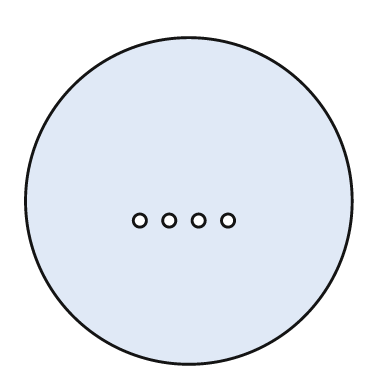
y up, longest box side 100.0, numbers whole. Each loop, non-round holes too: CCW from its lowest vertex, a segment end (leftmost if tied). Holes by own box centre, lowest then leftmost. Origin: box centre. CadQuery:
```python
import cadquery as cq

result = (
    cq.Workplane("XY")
    .moveTo(0.0, 0.0)
    .circle(50.0)
    .moveTo(-15.0, -6.0)
    .circle(2.0)
    .moveTo(-6.0, -6.0)
    .circle(2.0)
    .moveTo(3.0, -6.0)
    .circle(2.0)
    .moveTo(12.0, -6.0)
    .circle(2.0)
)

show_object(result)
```